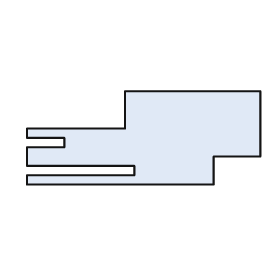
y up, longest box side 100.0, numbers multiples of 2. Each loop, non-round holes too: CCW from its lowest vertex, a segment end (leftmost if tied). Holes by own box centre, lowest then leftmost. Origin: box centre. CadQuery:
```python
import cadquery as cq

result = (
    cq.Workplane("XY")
    .moveTo(-50.0, -20.0)
    .lineTo(30.0, -20.0)
    .lineTo(30.0, -8.0)
    .lineTo(50.0, -8.0)
    .lineTo(50.0, 20.0)
    .lineTo(-8.0, 20.0)
    .lineTo(-8.0, 4.0)
    .lineTo(-50.0, 4.0)
    .lineTo(-50.0, 0.0)
    .lineTo(-34.0, 0.0)
    .lineTo(-34.0, -4.0)
    .lineTo(-50.0, -4.0)
    .lineTo(-50.0, -12.0)
    .lineTo(-4.0, -12.0)
    .lineTo(-4.0, -16.0)
    .lineTo(-50.0, -16.0)
    .close()
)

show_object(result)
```